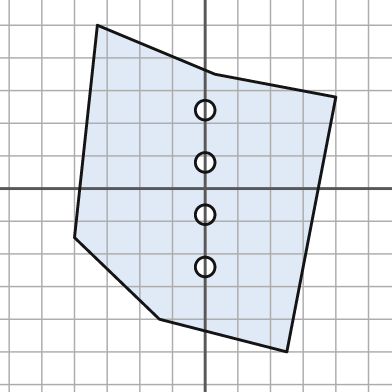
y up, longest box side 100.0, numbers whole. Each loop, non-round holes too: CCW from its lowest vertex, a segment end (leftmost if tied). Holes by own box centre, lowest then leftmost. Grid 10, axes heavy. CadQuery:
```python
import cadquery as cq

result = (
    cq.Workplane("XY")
    .moveTo(25.0, -50.0)
    .lineTo(40.0, 28.0)
    .lineTo(3.0, 35.0)
    .lineTo(-33.0, 50.0)
    .lineTo(-40.0, -15.0)
    .lineTo(-14.0, -40.0)
    .close()
    .moveTo(0.0, -24.0)
    .circle(3.0)
    .moveTo(0.0, -8.0)
    .circle(3.0)
    .moveTo(0.0, 8.0)
    .circle(3.0)
    .moveTo(0.0, 24.0)
    .circle(3.0)
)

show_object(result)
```